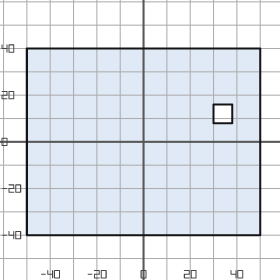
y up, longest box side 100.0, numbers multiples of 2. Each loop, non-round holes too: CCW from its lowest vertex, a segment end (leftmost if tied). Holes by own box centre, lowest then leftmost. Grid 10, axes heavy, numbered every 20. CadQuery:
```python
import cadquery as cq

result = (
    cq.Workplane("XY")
    .moveTo(-50.0, -40.0)
    .lineTo(50.0, -40.0)
    .lineTo(50.0, 40.0)
    .lineTo(-50.0, 40.0)
    .close()
    .moveTo(30.0, 8.0)
    .lineTo(38.0, 8.0)
    .lineTo(38.0, 16.0)
    .lineTo(30.0, 16.0)
    .close()
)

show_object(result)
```